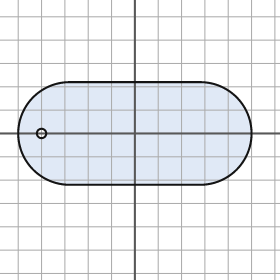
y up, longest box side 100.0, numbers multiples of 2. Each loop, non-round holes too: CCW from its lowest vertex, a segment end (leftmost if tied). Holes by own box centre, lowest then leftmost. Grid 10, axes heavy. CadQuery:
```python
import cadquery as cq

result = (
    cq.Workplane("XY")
    .moveTo(-28.0, -22.0)
    .lineTo(28.0, -22.0)
    .threePointArc((50.0, 0.0), (28.0, 22.0))
    .lineTo(-28.0, 22.0)
    .threePointArc((-50.0, 0.0), (-28.0, -22.0))
    .close()
    .moveTo(-40.0, 0.0)
    .circle(2.0)
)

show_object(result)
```